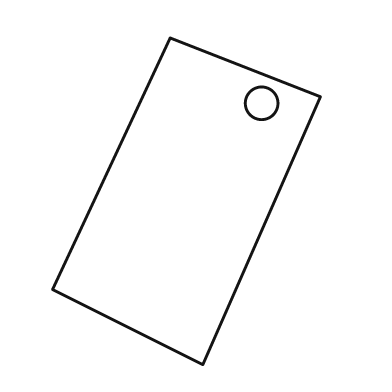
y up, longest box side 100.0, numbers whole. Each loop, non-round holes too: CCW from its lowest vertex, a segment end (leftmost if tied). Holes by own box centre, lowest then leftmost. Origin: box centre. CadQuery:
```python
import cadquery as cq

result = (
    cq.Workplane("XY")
    .moveTo(5.0, -50.0)
    .lineTo(41.0, 32.0)
    .lineTo(-5.0, 50.0)
    .lineTo(-41.0, -27.0)
    .close()
    .moveTo(23.0, 30.0)
    .circle(5.0)
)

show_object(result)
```